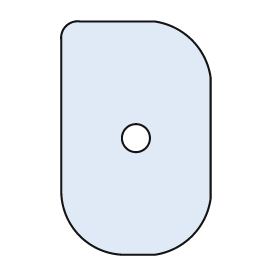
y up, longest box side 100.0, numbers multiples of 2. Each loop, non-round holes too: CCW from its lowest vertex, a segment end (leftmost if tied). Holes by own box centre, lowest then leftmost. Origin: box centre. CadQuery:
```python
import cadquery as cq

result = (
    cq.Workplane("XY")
    .moveTo(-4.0, -50.0)
    .lineTo(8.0, -50.0)
    .threePointArc((24.0, -42.0), (32.0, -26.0))
    .lineTo(32.0, 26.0)
    .threePointArc((24.0, 42.0), (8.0, 50.0))
    .lineTo(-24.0, 50.0)
    .threePointArc((-30.0, 48.0), (-32.0, 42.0))
    .lineTo(-32.0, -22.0)
    .threePointArc((-24.0, -42.0), (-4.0, -50.0))
    .close()
    .moveTo(0.0, 0.0)
    .circle(6.0)
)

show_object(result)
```